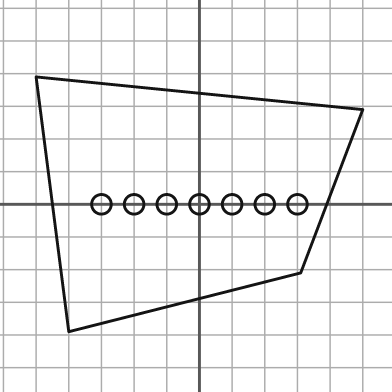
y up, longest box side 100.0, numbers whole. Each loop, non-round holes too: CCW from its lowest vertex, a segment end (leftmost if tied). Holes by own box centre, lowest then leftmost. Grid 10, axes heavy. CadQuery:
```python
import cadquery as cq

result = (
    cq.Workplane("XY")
    .moveTo(-40.0, -39.0)
    .lineTo(31.0, -21.0)
    .lineTo(50.0, 29.0)
    .lineTo(-50.0, 39.0)
    .close()
    .moveTo(-30.0, 0.0)
    .circle(3.0)
    .moveTo(-20.0, 0.0)
    .circle(3.0)
    .moveTo(-10.0, 0.0)
    .circle(3.0)
    .moveTo(0.0, 0.0)
    .circle(3.0)
    .moveTo(10.0, 0.0)
    .circle(3.0)
    .moveTo(20.0, 0.0)
    .circle(3.0)
    .moveTo(30.0, 0.0)
    .circle(3.0)
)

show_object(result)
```